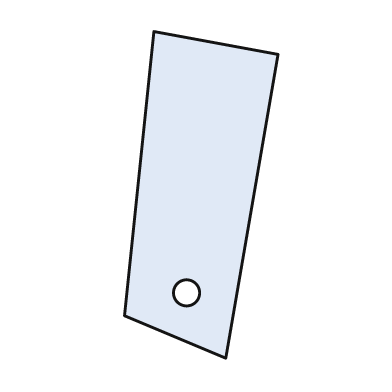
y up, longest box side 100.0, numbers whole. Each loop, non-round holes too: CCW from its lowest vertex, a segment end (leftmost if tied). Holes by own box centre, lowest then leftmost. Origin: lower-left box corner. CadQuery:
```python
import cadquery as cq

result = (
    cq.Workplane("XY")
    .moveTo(31.0, 0.0)
    .lineTo(47.0, 93.0)
    .lineTo(9.0, 100.0)
    .lineTo(0.0, 13.0)
    .close()
    .moveTo(19.0, 20.0)
    .circle(4.0)
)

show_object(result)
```